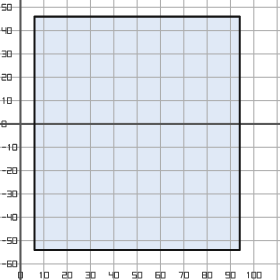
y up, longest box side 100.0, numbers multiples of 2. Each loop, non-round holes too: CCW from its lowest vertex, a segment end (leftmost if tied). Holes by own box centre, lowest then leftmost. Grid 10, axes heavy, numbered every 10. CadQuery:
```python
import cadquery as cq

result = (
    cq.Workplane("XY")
    .moveTo(6.0, -54.0)
    .lineTo(94.0, -54.0)
    .lineTo(94.0, 46.0)
    .lineTo(6.0, 46.0)
    .close()
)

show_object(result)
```